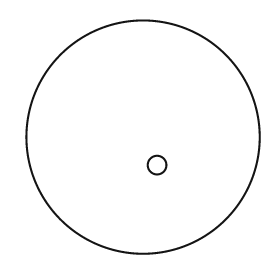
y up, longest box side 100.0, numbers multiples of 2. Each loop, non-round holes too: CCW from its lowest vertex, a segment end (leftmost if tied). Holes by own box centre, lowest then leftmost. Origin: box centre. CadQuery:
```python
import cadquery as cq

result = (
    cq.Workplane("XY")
    .moveTo(0.0, 0.0)
    .circle(50.0)
    .moveTo(6.0, -12.0)
    .circle(4.0)
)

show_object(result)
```